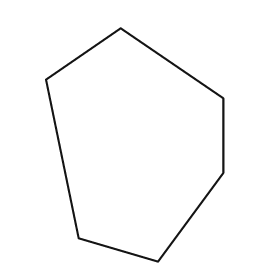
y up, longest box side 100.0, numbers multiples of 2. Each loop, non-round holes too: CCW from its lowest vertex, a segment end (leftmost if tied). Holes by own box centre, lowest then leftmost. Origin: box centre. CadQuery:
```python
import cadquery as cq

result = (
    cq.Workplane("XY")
    .moveTo(10.0, -50.0)
    .lineTo(38.0, -12.0)
    .lineTo(38.0, 20.0)
    .lineTo(-6.0, 50.0)
    .lineTo(-38.0, 28.0)
    .lineTo(-24.0, -40.0)
    .close()
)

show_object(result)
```